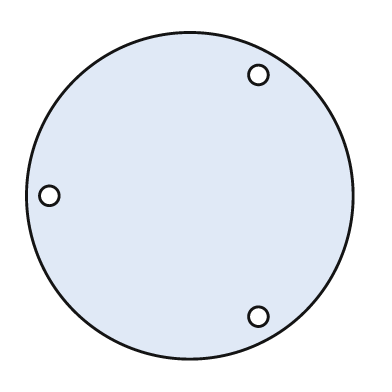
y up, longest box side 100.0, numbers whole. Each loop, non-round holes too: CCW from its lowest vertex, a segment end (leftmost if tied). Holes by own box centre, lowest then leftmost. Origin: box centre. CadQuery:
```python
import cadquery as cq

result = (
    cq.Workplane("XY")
    .moveTo(0.0, 0.0)
    .circle(50.0)
    .moveTo(21.0, -37.0)
    .circle(3.0)
    .moveTo(-43.0, 0.0)
    .circle(3.0)
    .moveTo(21.0, 37.0)
    .circle(3.0)
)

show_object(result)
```